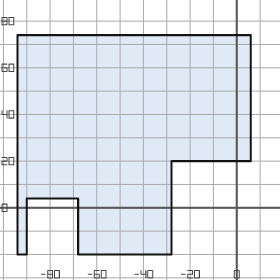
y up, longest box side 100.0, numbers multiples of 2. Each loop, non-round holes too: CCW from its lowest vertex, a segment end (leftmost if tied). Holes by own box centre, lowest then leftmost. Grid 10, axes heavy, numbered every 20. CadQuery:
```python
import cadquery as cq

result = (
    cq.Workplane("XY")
    .moveTo(-94.0, -20.0)
    .lineTo(-90.0, -20.0)
    .lineTo(-90.0, 4.0)
    .lineTo(-68.0, 4.0)
    .lineTo(-68.0, -20.0)
    .lineTo(-28.0, -20.0)
    .lineTo(-28.0, 20.0)
    .lineTo(6.0, 20.0)
    .lineTo(6.0, 74.0)
    .lineTo(-94.0, 74.0)
    .close()
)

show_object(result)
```